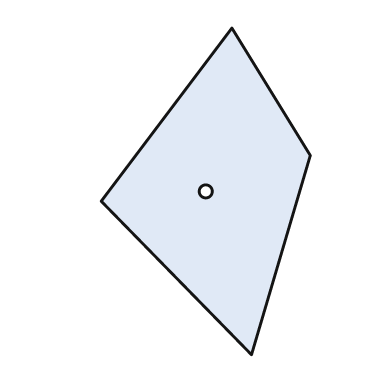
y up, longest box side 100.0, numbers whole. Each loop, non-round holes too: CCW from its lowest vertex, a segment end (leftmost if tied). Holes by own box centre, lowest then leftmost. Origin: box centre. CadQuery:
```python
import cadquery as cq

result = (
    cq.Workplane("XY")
    .moveTo(14.0, -50.0)
    .lineTo(32.0, 11.0)
    .lineTo(8.0, 50.0)
    .lineTo(-32.0, -3.0)
    .close()
    .moveTo(0.0, 0.0)
    .circle(2.0)
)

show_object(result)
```